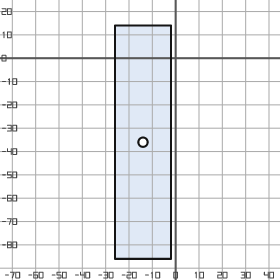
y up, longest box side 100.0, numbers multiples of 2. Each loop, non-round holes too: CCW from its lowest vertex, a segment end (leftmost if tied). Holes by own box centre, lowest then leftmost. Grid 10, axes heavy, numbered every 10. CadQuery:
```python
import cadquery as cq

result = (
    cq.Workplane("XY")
    .moveTo(-26.0, -86.0)
    .lineTo(-2.0, -86.0)
    .lineTo(-2.0, 14.0)
    .lineTo(-26.0, 14.0)
    .close()
    .moveTo(-14.0, -36.0)
    .circle(2.0)
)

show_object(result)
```